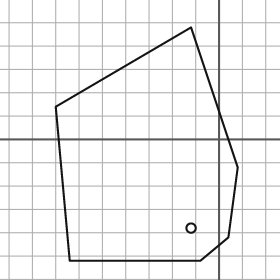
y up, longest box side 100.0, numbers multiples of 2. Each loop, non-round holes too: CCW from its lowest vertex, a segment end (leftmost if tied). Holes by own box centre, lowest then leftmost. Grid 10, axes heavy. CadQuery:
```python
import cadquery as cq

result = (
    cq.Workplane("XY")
    .moveTo(-64.0, -52.0)
    .lineTo(-8.0, -52.0)
    .lineTo(4.0, -42.0)
    .lineTo(8.0, -12.0)
    .lineTo(-12.0, 48.0)
    .lineTo(-70.0, 14.0)
    .close()
    .moveTo(-12.0, -38.0)
    .circle(2.0)
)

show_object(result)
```